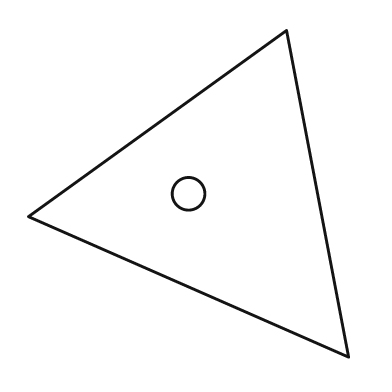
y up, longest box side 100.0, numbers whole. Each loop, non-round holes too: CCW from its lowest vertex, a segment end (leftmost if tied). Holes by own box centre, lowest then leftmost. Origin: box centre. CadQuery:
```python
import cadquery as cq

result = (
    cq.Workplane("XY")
    .moveTo(49.0, -50.0)
    .lineTo(30.0, 50.0)
    .lineTo(-49.0, -7.0)
    .close()
    .moveTo(0.0, 0.0)
    .circle(5.0)
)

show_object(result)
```